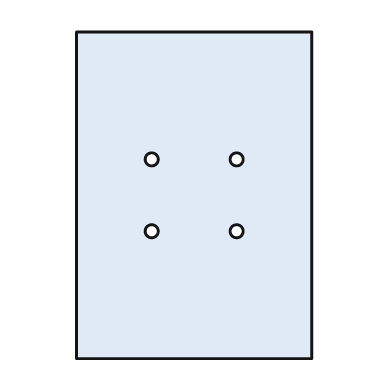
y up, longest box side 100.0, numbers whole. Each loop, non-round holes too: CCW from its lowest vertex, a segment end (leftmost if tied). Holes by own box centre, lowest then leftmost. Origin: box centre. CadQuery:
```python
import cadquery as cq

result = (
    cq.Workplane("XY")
    .moveTo(-36.0, -50.0)
    .lineTo(36.0, -50.0)
    .lineTo(36.0, 50.0)
    .lineTo(-36.0, 50.0)
    .close()
    .moveTo(-13.0, -11.0)
    .circle(2.0)
    .moveTo(13.0, -11.0)
    .circle(2.0)
    .moveTo(-13.0, 11.0)
    .circle(2.0)
    .moveTo(13.0, 11.0)
    .circle(2.0)
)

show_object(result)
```